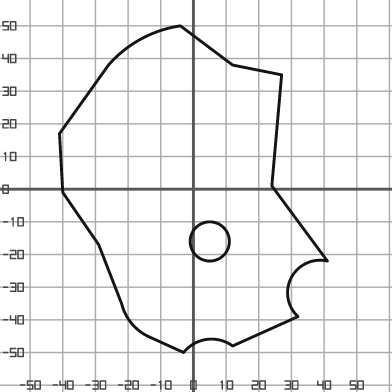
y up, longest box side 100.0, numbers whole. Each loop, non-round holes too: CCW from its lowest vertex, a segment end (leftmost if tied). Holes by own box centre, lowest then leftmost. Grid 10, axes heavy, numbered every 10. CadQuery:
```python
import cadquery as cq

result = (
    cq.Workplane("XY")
    .moveTo(-3.0, -50.0)
    .threePointArc((4.0, -46.0), (12.0, -48.0))
    .lineTo(32.0, -39.0)
    .threePointArc((30.0, -27.0), (41.0, -22.0))
    .lineTo(24.0, 1.0)
    .lineTo(27.0, 35.0)
    .lineTo(12.0, 38.0)
    .lineTo(-4.0, 50.0)
    .threePointArc((-16.0, 46.0), (-26.0, 38.0))
    .lineTo(-41.0, 17.0)
    .lineTo(-40.0, -1.0)
    .lineTo(-29.0, -17.0)
    .lineTo(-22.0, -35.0)
    .threePointArc((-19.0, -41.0), (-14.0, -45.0))
    .close()
    .moveTo(5.0, -16.0)
    .circle(6.0)
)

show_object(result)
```